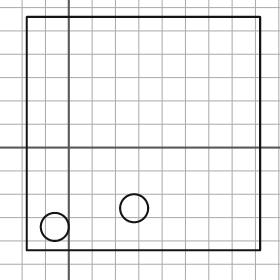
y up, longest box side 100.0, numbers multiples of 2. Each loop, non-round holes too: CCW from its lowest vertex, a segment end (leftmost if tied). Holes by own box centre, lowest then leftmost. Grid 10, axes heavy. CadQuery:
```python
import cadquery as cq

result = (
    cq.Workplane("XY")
    .moveTo(-18.0, -44.0)
    .lineTo(82.0, -44.0)
    .lineTo(82.0, 56.0)
    .lineTo(-18.0, 56.0)
    .close()
    .moveTo(-6.0, -34.0)
    .circle(6.0)
    .moveTo(28.0, -26.0)
    .circle(6.0)
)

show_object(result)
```